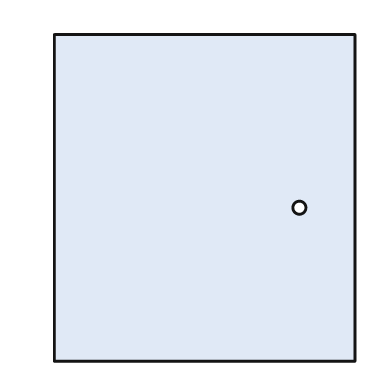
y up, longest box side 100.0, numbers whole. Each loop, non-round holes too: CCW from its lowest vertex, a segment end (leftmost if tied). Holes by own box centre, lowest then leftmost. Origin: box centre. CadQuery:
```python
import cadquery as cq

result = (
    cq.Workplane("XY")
    .moveTo(-46.0, -50.0)
    .lineTo(46.0, -50.0)
    .lineTo(46.0, 50.0)
    .lineTo(-46.0, 50.0)
    .close()
    .moveTo(29.0, -3.0)
    .circle(2.0)
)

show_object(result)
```